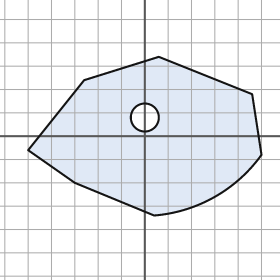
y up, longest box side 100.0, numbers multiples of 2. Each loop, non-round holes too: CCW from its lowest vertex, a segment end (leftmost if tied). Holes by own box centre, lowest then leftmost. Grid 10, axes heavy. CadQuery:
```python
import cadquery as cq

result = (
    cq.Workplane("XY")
    .moveTo(4.0, -34.0)
    .threePointArc((30.0, -26.0), (50.0, -8.0))
    .lineTo(46.0, 18.0)
    .lineTo(6.0, 34.0)
    .lineTo(-26.0, 24.0)
    .lineTo(-50.0, -6.0)
    .lineTo(-30.0, -20.0)
    .close()
    .moveTo(0.0, 8.0)
    .circle(6.0)
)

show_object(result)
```